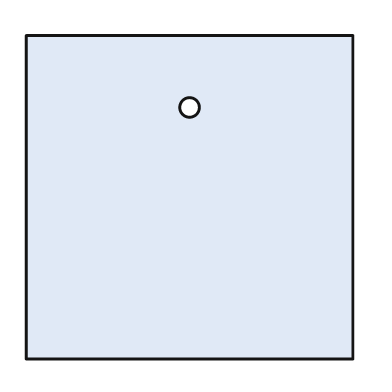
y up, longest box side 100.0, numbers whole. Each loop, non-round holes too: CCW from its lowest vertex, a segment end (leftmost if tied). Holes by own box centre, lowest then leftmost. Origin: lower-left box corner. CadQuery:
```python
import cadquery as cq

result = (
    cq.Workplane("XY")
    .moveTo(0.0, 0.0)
    .lineTo(100.0, 0.0)
    .lineTo(100.0, 99.0)
    .lineTo(0.0, 99.0)
    .close()
    .moveTo(50.0, 77.0)
    .circle(3.0)
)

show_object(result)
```